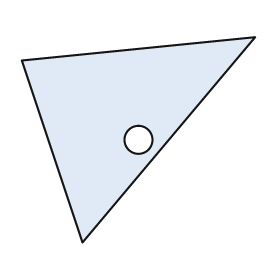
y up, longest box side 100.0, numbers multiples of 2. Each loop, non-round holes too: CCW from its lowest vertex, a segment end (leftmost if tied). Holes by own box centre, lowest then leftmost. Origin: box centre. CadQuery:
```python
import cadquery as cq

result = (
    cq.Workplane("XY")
    .moveTo(-24.0, -44.0)
    .lineTo(50.0, 44.0)
    .lineTo(-50.0, 34.0)
    .close()
    .moveTo(0.0, 0.0)
    .circle(6.0)
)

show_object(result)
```